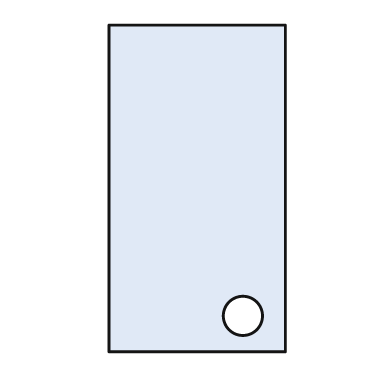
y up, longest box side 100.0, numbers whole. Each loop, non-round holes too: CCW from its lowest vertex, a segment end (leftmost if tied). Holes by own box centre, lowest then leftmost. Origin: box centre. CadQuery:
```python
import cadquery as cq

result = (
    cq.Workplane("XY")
    .moveTo(-27.0, -50.0)
    .lineTo(27.0, -50.0)
    .lineTo(27.0, 50.0)
    .lineTo(-27.0, 50.0)
    .close()
    .moveTo(14.0, -39.0)
    .circle(6.0)
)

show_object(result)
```